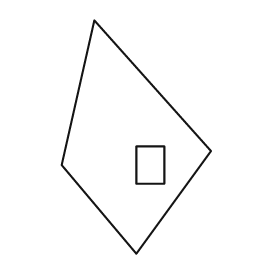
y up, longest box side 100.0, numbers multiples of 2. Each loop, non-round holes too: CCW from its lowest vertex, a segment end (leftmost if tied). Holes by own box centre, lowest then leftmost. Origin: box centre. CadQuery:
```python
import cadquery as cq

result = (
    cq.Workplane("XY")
    .moveTo(0.0, -50.0)
    .lineTo(32.0, -6.0)
    .lineTo(-18.0, 50.0)
    .lineTo(-32.0, -12.0)
    .close()
    .moveTo(0.0, -20.0)
    .lineTo(12.0, -20.0)
    .lineTo(12.0, -4.0)
    .lineTo(0.0, -4.0)
    .close()
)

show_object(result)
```